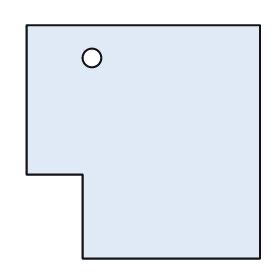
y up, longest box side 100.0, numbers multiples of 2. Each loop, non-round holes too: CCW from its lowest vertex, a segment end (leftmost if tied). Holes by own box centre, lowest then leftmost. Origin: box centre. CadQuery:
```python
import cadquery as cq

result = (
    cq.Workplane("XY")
    .moveTo(-26.0, -50.0)
    .lineTo(50.0, -50.0)
    .lineTo(50.0, 50.0)
    .lineTo(-50.0, 50.0)
    .lineTo(-50.0, -14.0)
    .lineTo(-26.0, -14.0)
    .close()
    .moveTo(-22.0, 36.0)
    .circle(4.0)
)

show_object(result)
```